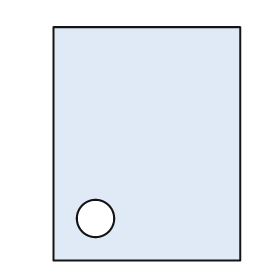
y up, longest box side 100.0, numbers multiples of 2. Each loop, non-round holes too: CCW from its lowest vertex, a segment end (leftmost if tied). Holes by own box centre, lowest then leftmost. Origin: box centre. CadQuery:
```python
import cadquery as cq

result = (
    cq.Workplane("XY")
    .moveTo(-40.0, -50.0)
    .lineTo(40.0, -50.0)
    .lineTo(40.0, 50.0)
    .lineTo(-40.0, 50.0)
    .close()
    .moveTo(-22.0, -32.0)
    .circle(8.0)
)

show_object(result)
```